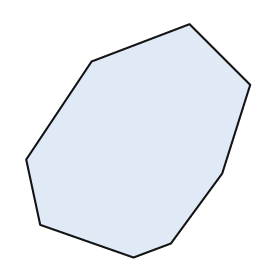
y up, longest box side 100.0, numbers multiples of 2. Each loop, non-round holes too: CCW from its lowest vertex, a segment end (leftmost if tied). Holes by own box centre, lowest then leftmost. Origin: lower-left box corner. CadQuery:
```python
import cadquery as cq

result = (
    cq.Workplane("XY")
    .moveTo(46.0, 0.0)
    .lineTo(62.0, 6.0)
    .lineTo(84.0, 36.0)
    .lineTo(96.0, 74.0)
    .lineTo(70.0, 100.0)
    .lineTo(28.0, 84.0)
    .lineTo(0.0, 42.0)
    .lineTo(6.0, 14.0)
    .close()
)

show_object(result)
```